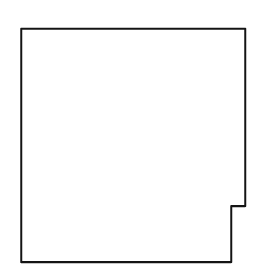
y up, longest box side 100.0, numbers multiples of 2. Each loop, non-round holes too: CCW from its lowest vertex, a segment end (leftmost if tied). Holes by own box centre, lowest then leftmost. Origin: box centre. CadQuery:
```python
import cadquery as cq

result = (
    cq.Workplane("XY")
    .moveTo(-48.0, -50.0)
    .lineTo(42.0, -50.0)
    .lineTo(42.0, -26.0)
    .lineTo(48.0, -26.0)
    .lineTo(48.0, 50.0)
    .lineTo(-48.0, 50.0)
    .close()
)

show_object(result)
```